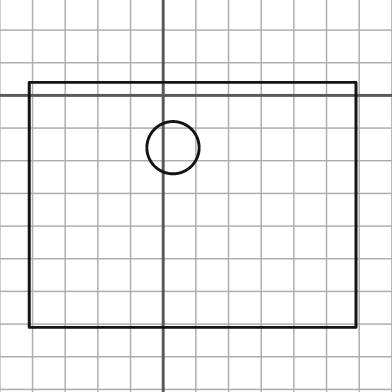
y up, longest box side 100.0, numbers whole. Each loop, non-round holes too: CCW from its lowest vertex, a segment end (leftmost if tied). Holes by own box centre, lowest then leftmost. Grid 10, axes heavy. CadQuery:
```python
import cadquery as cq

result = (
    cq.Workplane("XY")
    .moveTo(-41.0, -71.0)
    .lineTo(59.0, -71.0)
    .lineTo(59.0, 4.0)
    .lineTo(-41.0, 4.0)
    .close()
    .moveTo(3.0, -16.0)
    .circle(8.0)
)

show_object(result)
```